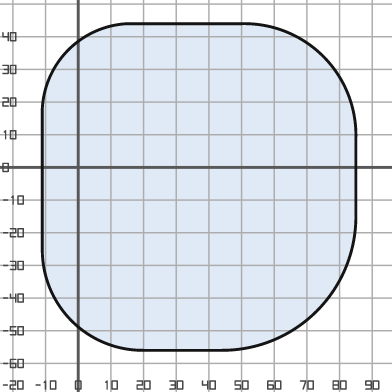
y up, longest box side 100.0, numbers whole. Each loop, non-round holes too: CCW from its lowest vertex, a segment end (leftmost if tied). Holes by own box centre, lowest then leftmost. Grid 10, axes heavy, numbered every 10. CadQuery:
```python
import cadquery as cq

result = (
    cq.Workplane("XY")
    .moveTo(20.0, -56.0)
    .lineTo(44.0, -56.0)
    .threePointArc((73.0, -44.0), (85.0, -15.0))
    .lineTo(85.0, 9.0)
    .threePointArc((75.0, 34.0), (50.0, 44.0))
    .lineTo(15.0, 44.0)
    .threePointArc((-3.0, 36.0), (-11.0, 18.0))
    .lineTo(-11.0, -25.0)
    .threePointArc((-2.0, -47.0), (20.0, -56.0))
    .close()
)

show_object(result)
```